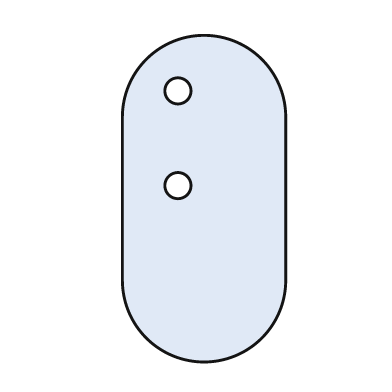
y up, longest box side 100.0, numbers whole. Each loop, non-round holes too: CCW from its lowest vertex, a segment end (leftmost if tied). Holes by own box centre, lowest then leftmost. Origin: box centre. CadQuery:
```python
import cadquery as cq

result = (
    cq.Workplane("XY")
    .moveTo(-25.0, -25.0)
    .threePointArc((0.0, -50.0), (25.0, -25.0))
    .lineTo(25.0, 25.0)
    .threePointArc((0.0, 50.0), (-25.0, 25.0))
    .close()
    .moveTo(-8.0, 4.0)
    .circle(4.0)
    .moveTo(-8.0, 33.0)
    .circle(4.0)
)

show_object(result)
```